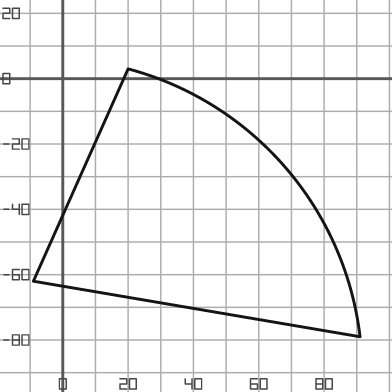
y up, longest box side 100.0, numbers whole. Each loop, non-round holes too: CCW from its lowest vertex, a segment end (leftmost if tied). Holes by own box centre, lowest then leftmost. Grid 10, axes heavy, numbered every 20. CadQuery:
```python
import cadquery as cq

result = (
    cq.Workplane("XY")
    .moveTo(91.0, -79.0)
    .threePointArc((68.0, -27.0), (20.0, 3.0))
    .lineTo(-9.0, -62.0)
    .close()
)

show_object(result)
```